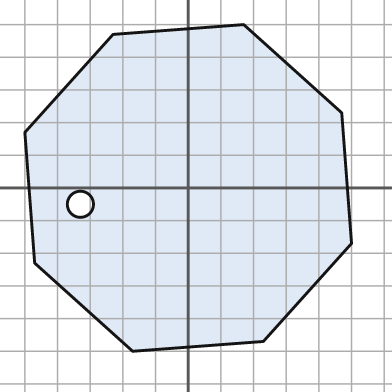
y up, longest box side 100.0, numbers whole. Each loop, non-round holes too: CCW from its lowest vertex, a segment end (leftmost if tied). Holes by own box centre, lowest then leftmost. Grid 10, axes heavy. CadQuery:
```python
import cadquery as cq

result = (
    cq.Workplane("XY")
    .moveTo(-17.0, -50.0)
    .lineTo(23.0, -47.0)
    .lineTo(50.0, -17.0)
    .lineTo(47.0, 23.0)
    .lineTo(17.0, 50.0)
    .lineTo(-23.0, 47.0)
    .lineTo(-50.0, 17.0)
    .lineTo(-47.0, -23.0)
    .close()
    .moveTo(-33.0, -5.0)
    .circle(4.0)
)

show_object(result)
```